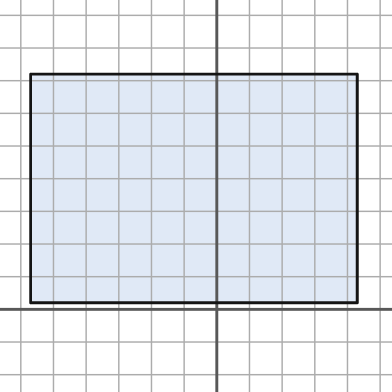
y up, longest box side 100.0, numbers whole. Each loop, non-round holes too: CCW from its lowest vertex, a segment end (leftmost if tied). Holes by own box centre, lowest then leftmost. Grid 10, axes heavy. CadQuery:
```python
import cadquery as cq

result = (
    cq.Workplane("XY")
    .moveTo(-57.0, 2.0)
    .lineTo(43.0, 2.0)
    .lineTo(43.0, 72.0)
    .lineTo(-57.0, 72.0)
    .close()
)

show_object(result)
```